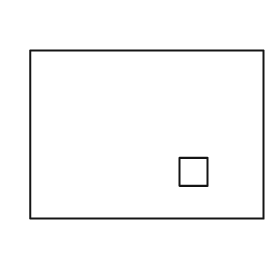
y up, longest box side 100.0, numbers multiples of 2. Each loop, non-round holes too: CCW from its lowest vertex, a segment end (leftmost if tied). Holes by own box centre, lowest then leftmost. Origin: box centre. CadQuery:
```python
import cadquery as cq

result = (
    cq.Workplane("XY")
    .moveTo(-50.0, -36.0)
    .lineTo(50.0, -36.0)
    .lineTo(50.0, 36.0)
    .lineTo(-50.0, 36.0)
    .close()
    .moveTo(14.0, -22.0)
    .lineTo(26.0, -22.0)
    .lineTo(26.0, -10.0)
    .lineTo(14.0, -10.0)
    .close()
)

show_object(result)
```